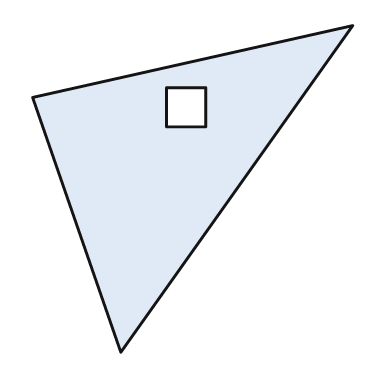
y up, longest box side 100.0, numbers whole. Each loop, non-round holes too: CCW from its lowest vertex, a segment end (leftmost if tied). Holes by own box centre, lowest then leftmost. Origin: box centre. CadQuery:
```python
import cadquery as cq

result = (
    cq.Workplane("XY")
    .moveTo(-22.0, -50.0)
    .lineTo(49.0, 50.0)
    .lineTo(-49.0, 28.0)
    .close()
    .moveTo(-8.0, 19.0)
    .lineTo(4.0, 19.0)
    .lineTo(4.0, 31.0)
    .lineTo(-8.0, 31.0)
    .close()
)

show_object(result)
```